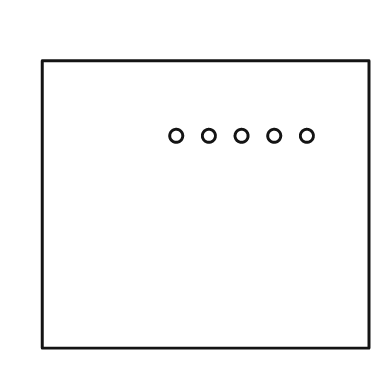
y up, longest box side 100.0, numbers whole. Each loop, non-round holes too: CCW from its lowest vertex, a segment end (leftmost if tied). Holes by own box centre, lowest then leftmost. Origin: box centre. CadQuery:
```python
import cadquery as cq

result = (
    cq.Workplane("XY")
    .moveTo(-50.0, -44.0)
    .lineTo(50.0, -44.0)
    .lineTo(50.0, 44.0)
    .lineTo(-50.0, 44.0)
    .close()
    .moveTo(-9.0, 21.0)
    .circle(2.0)
    .moveTo(1.0, 21.0)
    .circle(2.0)
    .moveTo(11.0, 21.0)
    .circle(2.0)
    .moveTo(21.0, 21.0)
    .circle(2.0)
    .moveTo(31.0, 21.0)
    .circle(2.0)
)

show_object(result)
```